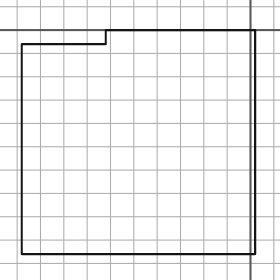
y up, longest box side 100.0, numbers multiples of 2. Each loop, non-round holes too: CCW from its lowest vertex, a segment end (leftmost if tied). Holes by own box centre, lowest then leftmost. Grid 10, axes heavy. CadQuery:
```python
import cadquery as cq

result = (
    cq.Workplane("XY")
    .moveTo(-98.0, -96.0)
    .lineTo(2.0, -96.0)
    .lineTo(2.0, 0.0)
    .lineTo(-62.0, 0.0)
    .lineTo(-62.0, -6.0)
    .lineTo(-98.0, -6.0)
    .close()
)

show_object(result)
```